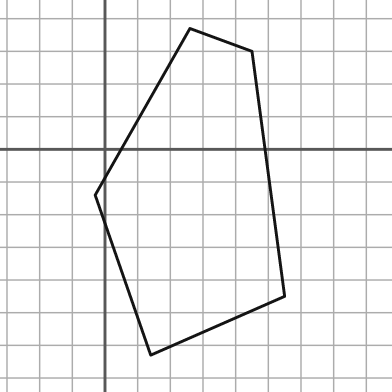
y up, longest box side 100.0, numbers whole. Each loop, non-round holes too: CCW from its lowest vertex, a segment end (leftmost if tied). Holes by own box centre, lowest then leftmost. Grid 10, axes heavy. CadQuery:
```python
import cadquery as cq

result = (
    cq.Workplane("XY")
    .moveTo(14.0, -63.0)
    .lineTo(55.0, -45.0)
    .lineTo(45.0, 30.0)
    .lineTo(26.0, 37.0)
    .lineTo(-3.0, -14.0)
    .close()
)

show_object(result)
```